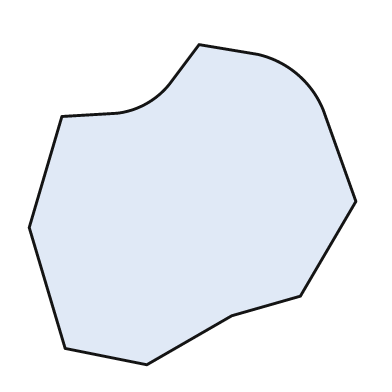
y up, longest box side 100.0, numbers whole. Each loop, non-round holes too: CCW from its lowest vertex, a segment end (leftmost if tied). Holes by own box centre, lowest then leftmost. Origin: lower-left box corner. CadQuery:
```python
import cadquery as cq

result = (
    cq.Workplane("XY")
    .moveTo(36.0, 0.0)
    .lineTo(62.0, 15.0)
    .lineTo(83.0, 21.0)
    .lineTo(100.0, 50.0)
    .lineTo(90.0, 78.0)
    .threePointArc((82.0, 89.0), (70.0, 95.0))
    .lineTo(52.0, 98.0)
    .lineTo(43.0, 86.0)
    .threePointArc((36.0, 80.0), (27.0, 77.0))
    .lineTo(10.0, 76.0)
    .lineTo(0.0, 42.0)
    .lineTo(11.0, 5.0)
    .close()
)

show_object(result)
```